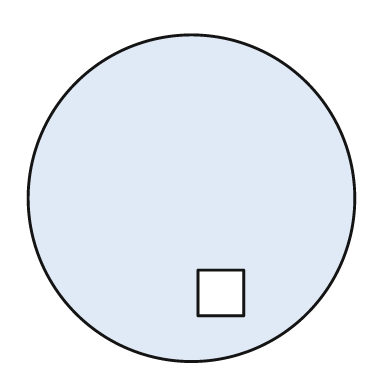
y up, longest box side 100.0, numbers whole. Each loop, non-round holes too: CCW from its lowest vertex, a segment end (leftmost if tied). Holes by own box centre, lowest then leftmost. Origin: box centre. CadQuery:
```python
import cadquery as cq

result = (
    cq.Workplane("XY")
    .moveTo(0.0, 0.0)
    .circle(50.0)
    .moveTo(2.0, -36.0)
    .lineTo(16.0, -36.0)
    .lineTo(16.0, -22.0)
    .lineTo(2.0, -22.0)
    .close()
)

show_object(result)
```